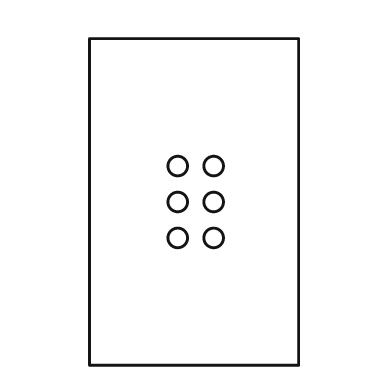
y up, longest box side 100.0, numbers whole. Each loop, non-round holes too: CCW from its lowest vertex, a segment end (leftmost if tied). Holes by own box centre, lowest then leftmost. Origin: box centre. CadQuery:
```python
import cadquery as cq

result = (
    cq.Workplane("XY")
    .moveTo(-32.0, -50.0)
    .lineTo(32.0, -50.0)
    .lineTo(32.0, 50.0)
    .lineTo(-32.0, 50.0)
    .close()
    .moveTo(-5.0, -11.0)
    .circle(3.0)
    .moveTo(6.0, -11.0)
    .circle(3.0)
    .moveTo(-5.0, 0.0)
    .circle(3.0)
    .moveTo(6.0, 0.0)
    .circle(3.0)
    .moveTo(-5.0, 11.0)
    .circle(3.0)
    .moveTo(6.0, 11.0)
    .circle(3.0)
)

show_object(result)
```